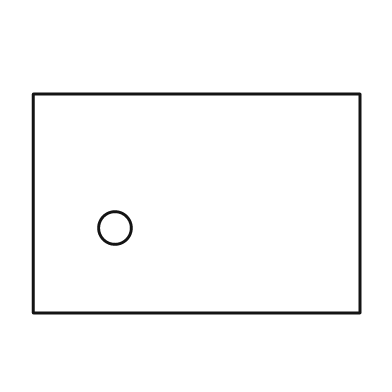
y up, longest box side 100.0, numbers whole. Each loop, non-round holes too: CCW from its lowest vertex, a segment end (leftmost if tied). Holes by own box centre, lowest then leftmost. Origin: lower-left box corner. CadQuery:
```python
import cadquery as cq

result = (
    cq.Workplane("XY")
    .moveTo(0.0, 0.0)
    .lineTo(100.0, 0.0)
    .lineTo(100.0, 67.0)
    .lineTo(0.0, 67.0)
    .close()
    .moveTo(25.0, 26.0)
    .circle(5.0)
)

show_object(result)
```